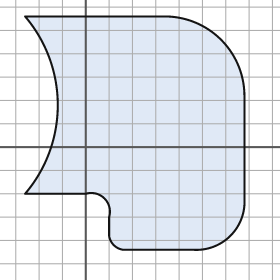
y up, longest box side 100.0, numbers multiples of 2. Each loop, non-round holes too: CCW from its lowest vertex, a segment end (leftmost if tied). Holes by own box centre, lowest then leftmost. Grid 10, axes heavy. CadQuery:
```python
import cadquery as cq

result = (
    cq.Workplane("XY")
    .moveTo(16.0, -44.0)
    .lineTo(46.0, -44.0)
    .threePointArc((62.0, -38.0), (68.0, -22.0))
    .lineTo(68.0, 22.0)
    .threePointArc((58.0, 46.0), (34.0, 56.0))
    .lineTo(-26.0, 56.0)
    .threePointArc((-12.0, 18.0), (-26.0, -20.0))
    .lineTo(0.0, -20.0)
    .threePointArc((8.0, -22.0), (10.0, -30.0))
    .lineTo(10.0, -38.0)
    .threePointArc((12.0, -42.0), (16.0, -44.0))
    .close()
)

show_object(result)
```